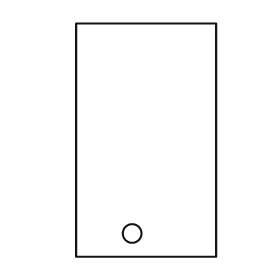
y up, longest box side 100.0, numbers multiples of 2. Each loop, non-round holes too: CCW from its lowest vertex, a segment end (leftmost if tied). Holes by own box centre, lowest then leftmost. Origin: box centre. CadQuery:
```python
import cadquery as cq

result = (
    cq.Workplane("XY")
    .moveTo(-30.0, -50.0)
    .lineTo(30.0, -50.0)
    .lineTo(30.0, 50.0)
    .lineTo(-30.0, 50.0)
    .close()
    .moveTo(-6.0, -40.0)
    .circle(4.0)
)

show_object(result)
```